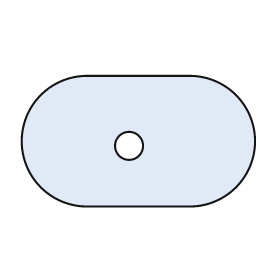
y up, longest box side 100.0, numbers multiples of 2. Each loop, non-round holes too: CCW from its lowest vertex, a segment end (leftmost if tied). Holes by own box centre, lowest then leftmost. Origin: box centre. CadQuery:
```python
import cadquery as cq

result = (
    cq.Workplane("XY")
    .moveTo(-22.0, -28.0)
    .lineTo(22.0, -28.0)
    .threePointArc((50.0, 0.0), (22.0, 28.0))
    .lineTo(-22.0, 28.0)
    .threePointArc((-50.0, 0.0), (-22.0, -28.0))
    .close()
    .moveTo(-4.0, -2.0)
    .circle(6.0)
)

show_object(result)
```